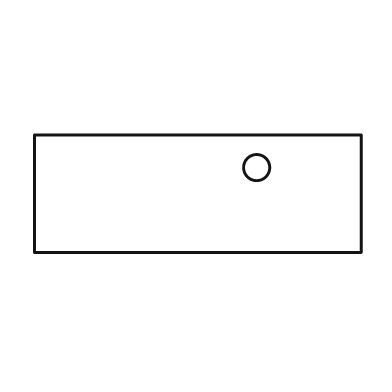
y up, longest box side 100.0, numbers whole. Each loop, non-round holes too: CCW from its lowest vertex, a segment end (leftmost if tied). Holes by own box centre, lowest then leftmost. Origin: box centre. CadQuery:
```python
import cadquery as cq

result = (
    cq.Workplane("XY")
    .moveTo(-50.0, -18.0)
    .lineTo(50.0, -18.0)
    .lineTo(50.0, 18.0)
    .lineTo(-50.0, 18.0)
    .close()
    .moveTo(18.0, 8.0)
    .circle(4.0)
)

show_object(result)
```